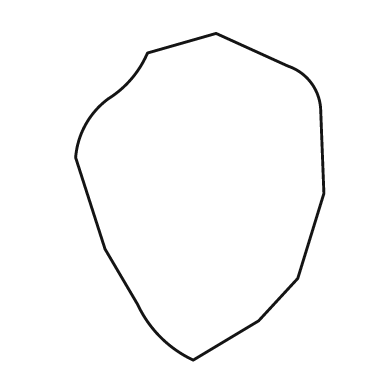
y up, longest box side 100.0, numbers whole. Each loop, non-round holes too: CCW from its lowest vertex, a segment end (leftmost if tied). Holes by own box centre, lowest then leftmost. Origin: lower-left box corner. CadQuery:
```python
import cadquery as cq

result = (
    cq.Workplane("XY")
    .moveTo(36.0, 0.0)
    .lineTo(56.0, 12.0)
    .lineTo(68.0, 25.0)
    .lineTo(76.0, 51.0)
    .lineTo(75.0, 77.0)
    .threePointArc((72.0, 85.0), (65.0, 90.0))
    .lineTo(43.0, 100.0)
    .lineTo(22.0, 94.0)
    .threePointArc((17.0, 86.0), (10.0, 80.0))
    .threePointArc((3.0, 72.0), (0.0, 62.0))
    .lineTo(9.0, 34.0)
    .lineTo(19.0, 17.0)
    .threePointArc((26.0, 7.0), (36.0, 0.0))
    .close()
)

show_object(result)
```